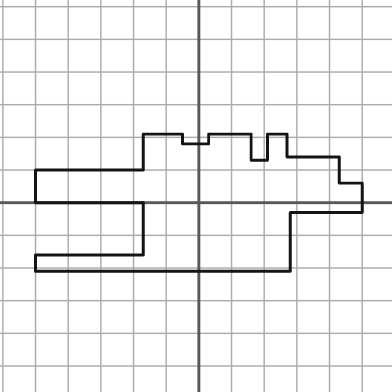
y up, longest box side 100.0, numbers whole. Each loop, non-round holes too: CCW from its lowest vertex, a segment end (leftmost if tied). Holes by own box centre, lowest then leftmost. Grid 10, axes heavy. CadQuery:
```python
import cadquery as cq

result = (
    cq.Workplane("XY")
    .moveTo(-50.0, -21.0)
    .lineTo(28.0, -21.0)
    .lineTo(28.0, -3.0)
    .lineTo(50.0, -3.0)
    .lineTo(50.0, 6.0)
    .lineTo(43.0, 6.0)
    .lineTo(43.0, 14.0)
    .lineTo(27.0, 14.0)
    .lineTo(27.0, 21.0)
    .lineTo(21.0, 21.0)
    .lineTo(21.0, 13.0)
    .lineTo(16.0, 13.0)
    .lineTo(16.0, 21.0)
    .lineTo(3.0, 21.0)
    .lineTo(3.0, 18.0)
    .lineTo(-5.0, 18.0)
    .lineTo(-5.0, 21.0)
    .lineTo(-17.0, 21.0)
    .lineTo(-17.0, 10.0)
    .lineTo(-50.0, 10.0)
    .lineTo(-50.0, 0.0)
    .lineTo(-17.0, 0.0)
    .lineTo(-17.0, -16.0)
    .lineTo(-50.0, -16.0)
    .close()
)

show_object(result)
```